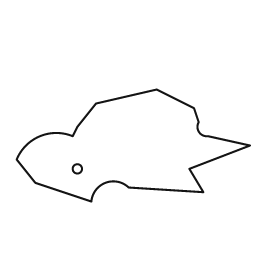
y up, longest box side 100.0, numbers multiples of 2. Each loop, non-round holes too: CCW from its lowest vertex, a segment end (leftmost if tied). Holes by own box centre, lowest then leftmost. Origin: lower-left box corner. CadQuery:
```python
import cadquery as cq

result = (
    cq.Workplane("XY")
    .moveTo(32.0, 0.0)
    .threePointArc((38.0, 8.0), (48.0, 6.0))
    .lineTo(80.0, 4.0)
    .lineTo(74.0, 14.0)
    .lineTo(100.0, 24.0)
    .lineTo(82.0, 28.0)
    .threePointArc((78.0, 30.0), (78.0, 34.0))
    .lineTo(76.0, 40.0)
    .lineTo(60.0, 48.0)
    .lineTo(34.0, 42.0)
    .lineTo(26.0, 32.0)
    .lineTo(24.0, 28.0)
    .threePointArc((10.0, 28.0), (0.0, 18.0))
    .lineTo(8.0, 8.0)
    .close()
    .moveTo(26.0, 14.0)
    .circle(2.0)
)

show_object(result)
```